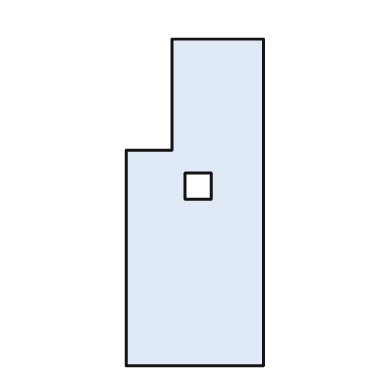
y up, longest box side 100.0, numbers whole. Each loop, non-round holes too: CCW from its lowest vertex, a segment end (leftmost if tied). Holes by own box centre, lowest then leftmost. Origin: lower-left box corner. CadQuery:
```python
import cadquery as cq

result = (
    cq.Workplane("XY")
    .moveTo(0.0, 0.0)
    .lineTo(42.0, 0.0)
    .lineTo(42.0, 100.0)
    .lineTo(14.0, 100.0)
    .lineTo(14.0, 66.0)
    .lineTo(0.0, 66.0)
    .close()
    .moveTo(18.0, 51.0)
    .lineTo(26.0, 51.0)
    .lineTo(26.0, 59.0)
    .lineTo(18.0, 59.0)
    .close()
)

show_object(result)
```